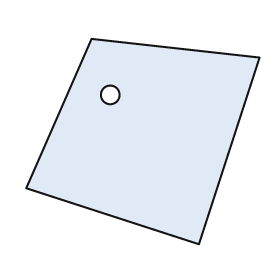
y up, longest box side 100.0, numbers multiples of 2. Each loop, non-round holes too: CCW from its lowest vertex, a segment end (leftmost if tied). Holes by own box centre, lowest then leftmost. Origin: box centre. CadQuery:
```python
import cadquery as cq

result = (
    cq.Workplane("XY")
    .moveTo(24.0, -44.0)
    .lineTo(50.0, 36.0)
    .lineTo(-22.0, 44.0)
    .lineTo(-50.0, -20.0)
    .close()
    .moveTo(-14.0, 20.0)
    .circle(4.0)
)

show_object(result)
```